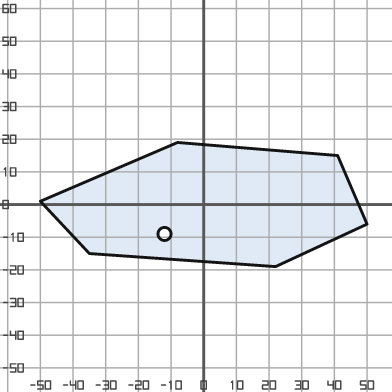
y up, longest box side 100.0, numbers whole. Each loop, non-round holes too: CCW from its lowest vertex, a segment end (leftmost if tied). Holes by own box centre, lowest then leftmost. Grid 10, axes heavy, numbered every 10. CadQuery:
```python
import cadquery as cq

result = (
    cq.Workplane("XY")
    .moveTo(22.0, -19.0)
    .lineTo(50.0, -6.0)
    .lineTo(41.0, 15.0)
    .lineTo(-8.0, 19.0)
    .lineTo(-50.0, 1.0)
    .lineTo(-35.0, -15.0)
    .close()
    .moveTo(-12.0, -9.0)
    .circle(2.0)
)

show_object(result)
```